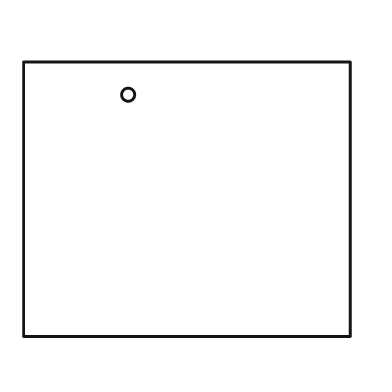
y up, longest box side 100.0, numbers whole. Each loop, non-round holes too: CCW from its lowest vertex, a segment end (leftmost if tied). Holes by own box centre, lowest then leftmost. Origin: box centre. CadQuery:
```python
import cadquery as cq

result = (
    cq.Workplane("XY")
    .moveTo(-50.0, -42.0)
    .lineTo(50.0, -42.0)
    .lineTo(50.0, 42.0)
    .lineTo(-50.0, 42.0)
    .close()
    .moveTo(-18.0, 32.0)
    .circle(2.0)
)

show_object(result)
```